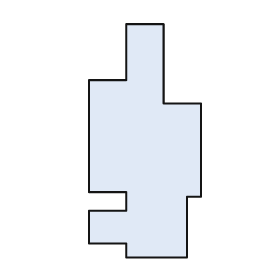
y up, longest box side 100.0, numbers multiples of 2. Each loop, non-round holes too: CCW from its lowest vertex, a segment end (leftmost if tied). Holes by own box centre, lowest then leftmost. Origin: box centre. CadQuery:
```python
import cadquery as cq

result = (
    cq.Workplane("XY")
    .moveTo(-8.0, -50.0)
    .lineTo(18.0, -50.0)
    .lineTo(18.0, -24.0)
    .lineTo(24.0, -24.0)
    .lineTo(24.0, 16.0)
    .lineTo(8.0, 16.0)
    .lineTo(8.0, 50.0)
    .lineTo(-8.0, 50.0)
    .lineTo(-8.0, 26.0)
    .lineTo(-24.0, 26.0)
    .lineTo(-24.0, -22.0)
    .lineTo(-8.0, -22.0)
    .lineTo(-8.0, -30.0)
    .lineTo(-24.0, -30.0)
    .lineTo(-24.0, -44.0)
    .lineTo(-8.0, -44.0)
    .close()
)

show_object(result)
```